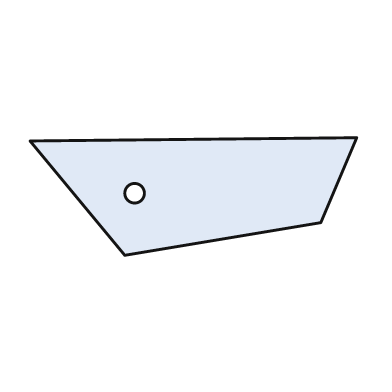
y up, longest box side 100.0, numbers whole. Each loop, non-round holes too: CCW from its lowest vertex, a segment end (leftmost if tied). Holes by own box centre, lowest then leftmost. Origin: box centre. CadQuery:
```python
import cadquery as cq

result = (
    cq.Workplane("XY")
    .moveTo(-21.0, -18.0)
    .lineTo(39.0, -8.0)
    .lineTo(50.0, 18.0)
    .lineTo(-50.0, 17.0)
    .close()
    .moveTo(-18.0, 1.0)
    .circle(3.0)
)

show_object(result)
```